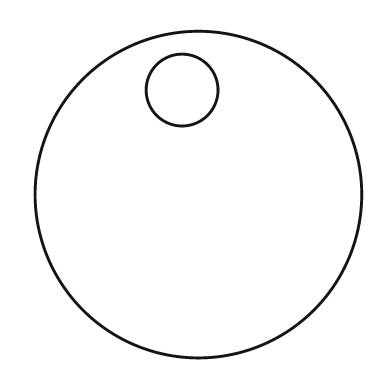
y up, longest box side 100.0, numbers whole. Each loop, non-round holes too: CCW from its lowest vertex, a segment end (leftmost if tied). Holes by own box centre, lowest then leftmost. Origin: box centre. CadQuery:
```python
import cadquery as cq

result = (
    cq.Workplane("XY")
    .moveTo(0.0, 0.0)
    .circle(50.0)
    .moveTo(-5.0, 32.0)
    .circle(11.0)
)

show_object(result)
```